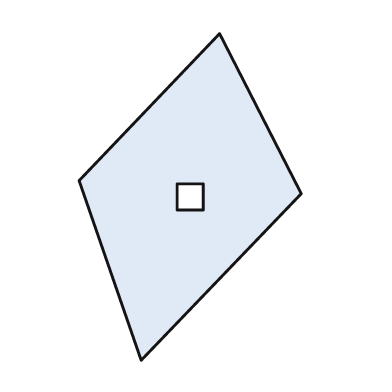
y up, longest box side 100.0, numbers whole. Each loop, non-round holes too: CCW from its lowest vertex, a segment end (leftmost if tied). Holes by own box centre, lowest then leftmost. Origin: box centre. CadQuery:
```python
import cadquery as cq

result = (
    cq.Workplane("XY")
    .moveTo(-15.0, -50.0)
    .lineTo(34.0, 1.0)
    .lineTo(9.0, 50.0)
    .lineTo(-34.0, 5.0)
    .close()
    .moveTo(-4.0, -4.0)
    .lineTo(4.0, -4.0)
    .lineTo(4.0, 4.0)
    .lineTo(-4.0, 4.0)
    .close()
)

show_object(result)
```